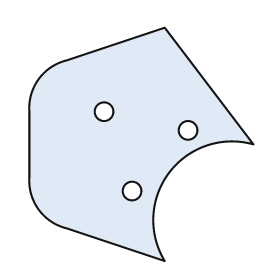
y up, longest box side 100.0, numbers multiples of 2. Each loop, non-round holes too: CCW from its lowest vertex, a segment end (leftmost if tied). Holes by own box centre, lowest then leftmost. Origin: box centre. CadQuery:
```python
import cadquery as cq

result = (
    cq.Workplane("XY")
    .moveTo(10.0, -50.0)
    .threePointArc((12.0, -12.0), (48.0, 0.0))
    .lineTo(10.0, 50.0)
    .lineTo(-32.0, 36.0)
    .threePointArc((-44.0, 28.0), (-48.0, 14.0))
    .lineTo(-48.0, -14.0)
    .threePointArc((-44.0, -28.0), (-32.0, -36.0))
    .close()
    .moveTo(-4.0, -20.0)
    .circle(4.0)
    .moveTo(20.0, 6.0)
    .circle(4.0)
    .moveTo(-16.0, 14.0)
    .circle(4.0)
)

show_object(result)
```